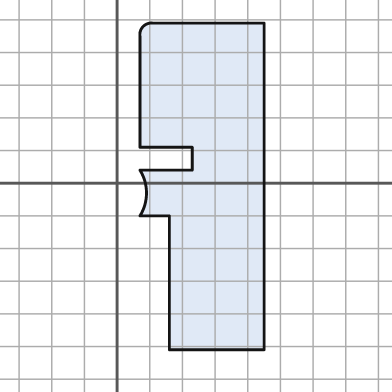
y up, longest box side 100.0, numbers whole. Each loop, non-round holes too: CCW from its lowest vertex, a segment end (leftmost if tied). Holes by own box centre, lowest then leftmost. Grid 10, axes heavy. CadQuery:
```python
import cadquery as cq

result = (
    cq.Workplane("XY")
    .moveTo(16.0, -51.0)
    .lineTo(45.0, -51.0)
    .lineTo(45.0, 49.0)
    .lineTo(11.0, 49.0)
    .threePointArc((8.0, 48.0), (7.0, 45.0))
    .lineTo(7.0, 11.0)
    .lineTo(23.0, 11.0)
    .lineTo(23.0, 4.0)
    .lineTo(7.0, 4.0)
    .threePointArc((9.0, -3.0), (7.0, -10.0))
    .lineTo(16.0, -10.0)
    .close()
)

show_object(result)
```